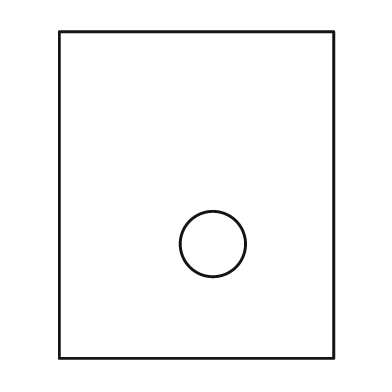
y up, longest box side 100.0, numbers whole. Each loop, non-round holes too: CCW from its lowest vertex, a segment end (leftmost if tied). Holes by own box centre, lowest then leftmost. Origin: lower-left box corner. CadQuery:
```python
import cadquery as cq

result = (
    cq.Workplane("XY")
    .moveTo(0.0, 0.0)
    .lineTo(84.0, 0.0)
    .lineTo(84.0, 100.0)
    .lineTo(0.0, 100.0)
    .close()
    .moveTo(47.0, 35.0)
    .circle(10.0)
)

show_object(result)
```